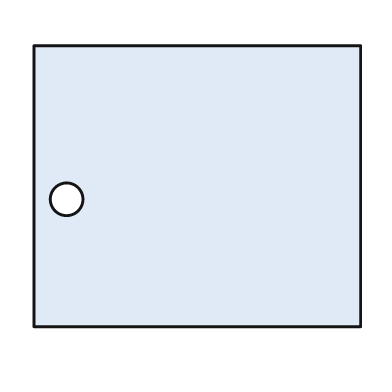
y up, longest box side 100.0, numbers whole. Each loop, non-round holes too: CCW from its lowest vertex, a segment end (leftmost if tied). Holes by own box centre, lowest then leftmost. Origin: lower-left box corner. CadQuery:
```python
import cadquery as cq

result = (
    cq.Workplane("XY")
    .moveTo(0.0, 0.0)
    .lineTo(100.0, 0.0)
    .lineTo(100.0, 86.0)
    .lineTo(0.0, 86.0)
    .close()
    .moveTo(10.0, 39.0)
    .circle(5.0)
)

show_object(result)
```